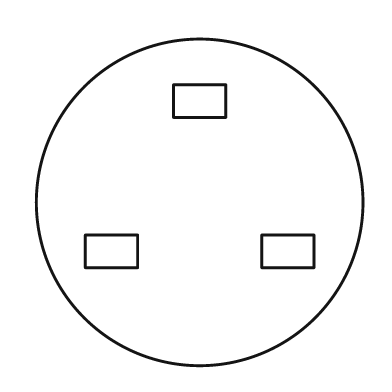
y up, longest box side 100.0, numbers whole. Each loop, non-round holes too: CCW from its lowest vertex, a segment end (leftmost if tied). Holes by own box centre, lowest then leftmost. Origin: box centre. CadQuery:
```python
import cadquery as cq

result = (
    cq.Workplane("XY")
    .moveTo(0.0, 0.0)
    .circle(50.0)
    .moveTo(-35.0, -20.0)
    .lineTo(-19.0, -20.0)
    .lineTo(-19.0, -10.0)
    .lineTo(-35.0, -10.0)
    .close()
    .moveTo(19.0, -20.0)
    .lineTo(35.0, -20.0)
    .lineTo(35.0, -10.0)
    .lineTo(19.0, -10.0)
    .close()
    .moveTo(-8.0, 26.0)
    .lineTo(8.0, 26.0)
    .lineTo(8.0, 36.0)
    .lineTo(-8.0, 36.0)
    .close()
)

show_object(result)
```